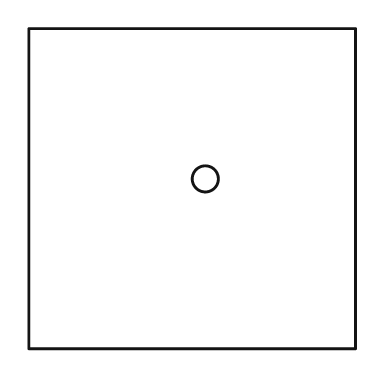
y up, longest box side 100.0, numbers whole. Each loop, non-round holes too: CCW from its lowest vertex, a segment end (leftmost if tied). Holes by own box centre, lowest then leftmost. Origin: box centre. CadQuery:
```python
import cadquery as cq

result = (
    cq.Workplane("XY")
    .moveTo(-50.0, -49.0)
    .lineTo(50.0, -49.0)
    .lineTo(50.0, 49.0)
    .lineTo(-50.0, 49.0)
    .close()
    .moveTo(4.0, 3.0)
    .circle(4.0)
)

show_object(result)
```